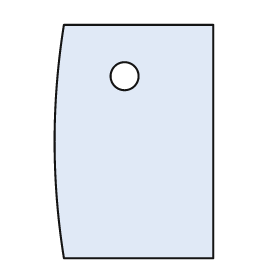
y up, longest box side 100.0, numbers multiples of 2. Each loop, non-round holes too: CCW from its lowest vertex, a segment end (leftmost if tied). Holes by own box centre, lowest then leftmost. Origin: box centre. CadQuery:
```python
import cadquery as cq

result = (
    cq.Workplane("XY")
    .moveTo(-30.0, -50.0)
    .lineTo(34.0, -50.0)
    .lineTo(34.0, 50.0)
    .lineTo(-30.0, 50.0)
    .threePointArc((-34.0, 0.0), (-30.0, -50.0))
    .close()
    .moveTo(-4.0, 28.0)
    .circle(6.0)
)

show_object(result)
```